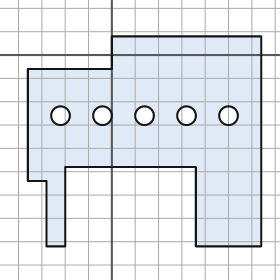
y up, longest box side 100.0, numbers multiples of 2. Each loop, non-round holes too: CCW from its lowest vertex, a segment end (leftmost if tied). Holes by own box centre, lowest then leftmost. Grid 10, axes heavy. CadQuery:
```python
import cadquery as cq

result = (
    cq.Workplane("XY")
    .moveTo(-28.0, -82.0)
    .lineTo(-20.0, -82.0)
    .lineTo(-20.0, -48.0)
    .lineTo(36.0, -48.0)
    .lineTo(36.0, -82.0)
    .lineTo(64.0, -82.0)
    .lineTo(64.0, 8.0)
    .lineTo(0.0, 8.0)
    .lineTo(0.0, -6.0)
    .lineTo(-36.0, -6.0)
    .lineTo(-36.0, -54.0)
    .lineTo(-28.0, -54.0)
    .close()
    .moveTo(-22.0, -26.0)
    .circle(4.0)
    .moveTo(-4.0, -26.0)
    .circle(4.0)
    .moveTo(14.0, -26.0)
    .circle(4.0)
    .moveTo(32.0, -26.0)
    .circle(4.0)
    .moveTo(50.0, -26.0)
    .circle(4.0)
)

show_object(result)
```